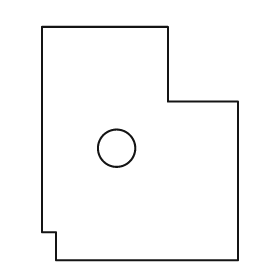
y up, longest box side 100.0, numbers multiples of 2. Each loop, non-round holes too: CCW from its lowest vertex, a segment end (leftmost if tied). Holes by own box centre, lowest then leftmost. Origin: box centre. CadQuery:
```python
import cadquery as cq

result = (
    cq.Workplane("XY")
    .moveTo(-36.0, -50.0)
    .lineTo(42.0, -50.0)
    .lineTo(42.0, 18.0)
    .lineTo(12.0, 18.0)
    .lineTo(12.0, 50.0)
    .lineTo(-42.0, 50.0)
    .lineTo(-42.0, -38.0)
    .lineTo(-36.0, -38.0)
    .close()
    .moveTo(-10.0, -2.0)
    .circle(8.0)
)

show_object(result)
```